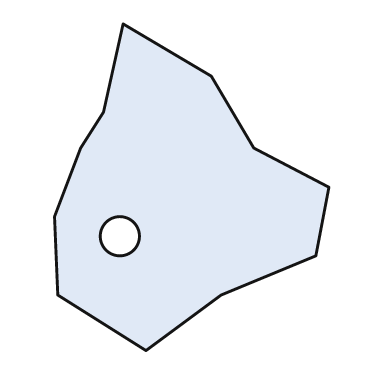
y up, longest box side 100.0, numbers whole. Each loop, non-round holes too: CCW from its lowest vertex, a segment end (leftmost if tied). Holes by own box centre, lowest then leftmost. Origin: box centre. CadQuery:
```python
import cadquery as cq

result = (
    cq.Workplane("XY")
    .moveTo(-14.0, -50.0)
    .lineTo(9.0, -33.0)
    .lineTo(38.0, -21.0)
    .lineTo(42.0, 0.0)
    .lineTo(19.0, 12.0)
    .lineTo(6.0, 34.0)
    .lineTo(-21.0, 50.0)
    .lineTo(-27.0, 23.0)
    .lineTo(-34.0, 12.0)
    .lineTo(-42.0, -9.0)
    .lineTo(-41.0, -33.0)
    .close()
    .moveTo(-22.0, -15.0)
    .circle(6.0)
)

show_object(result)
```